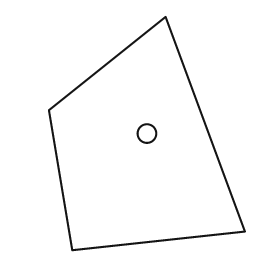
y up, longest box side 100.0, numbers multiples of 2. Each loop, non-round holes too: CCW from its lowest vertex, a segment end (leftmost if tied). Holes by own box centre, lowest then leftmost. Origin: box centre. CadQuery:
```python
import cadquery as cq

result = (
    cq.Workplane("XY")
    .moveTo(-32.0, -50.0)
    .lineTo(42.0, -42.0)
    .lineTo(8.0, 50.0)
    .lineTo(-42.0, 10.0)
    .close()
    .moveTo(0.0, 0.0)
    .circle(4.0)
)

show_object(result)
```